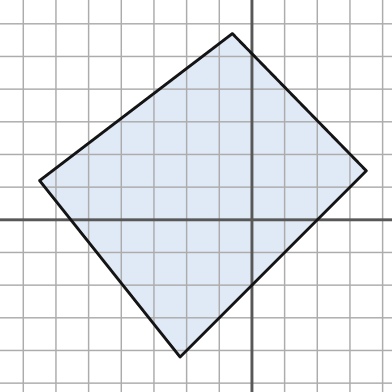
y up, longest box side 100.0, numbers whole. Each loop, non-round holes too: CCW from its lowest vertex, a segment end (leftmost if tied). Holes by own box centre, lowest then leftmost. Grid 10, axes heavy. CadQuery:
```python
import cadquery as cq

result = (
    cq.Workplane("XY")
    .moveTo(-22.0, -42.0)
    .lineTo(35.0, 15.0)
    .lineTo(-6.0, 57.0)
    .lineTo(-65.0, 12.0)
    .close()
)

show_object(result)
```